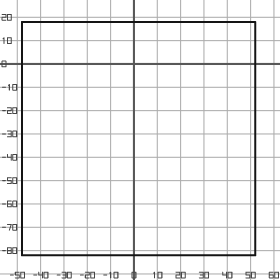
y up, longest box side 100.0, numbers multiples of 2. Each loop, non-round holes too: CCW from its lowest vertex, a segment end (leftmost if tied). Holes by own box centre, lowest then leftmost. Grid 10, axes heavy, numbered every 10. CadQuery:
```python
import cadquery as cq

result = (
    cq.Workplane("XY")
    .moveTo(-48.0, -82.0)
    .lineTo(52.0, -82.0)
    .lineTo(52.0, 18.0)
    .lineTo(-48.0, 18.0)
    .close()
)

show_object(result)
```